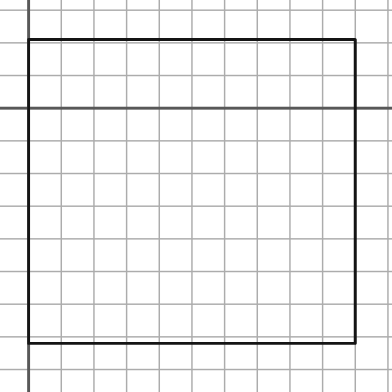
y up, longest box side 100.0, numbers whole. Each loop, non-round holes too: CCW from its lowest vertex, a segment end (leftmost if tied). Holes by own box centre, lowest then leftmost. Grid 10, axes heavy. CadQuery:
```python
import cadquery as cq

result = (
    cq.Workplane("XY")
    .moveTo(0.0, -72.0)
    .lineTo(100.0, -72.0)
    .lineTo(100.0, 21.0)
    .lineTo(0.0, 21.0)
    .close()
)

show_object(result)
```